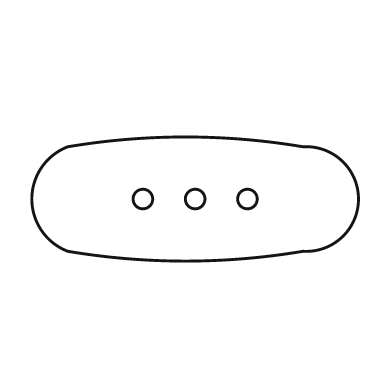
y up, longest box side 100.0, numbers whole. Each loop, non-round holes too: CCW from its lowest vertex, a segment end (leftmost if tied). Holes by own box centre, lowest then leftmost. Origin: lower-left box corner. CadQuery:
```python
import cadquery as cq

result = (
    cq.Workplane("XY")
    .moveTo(11.0, 3.0)
    .threePointArc((47.0, 0.0), (83.0, 3.0))
    .threePointArc((100.0, 19.0), (83.0, 35.0))
    .threePointArc((47.0, 38.0), (11.0, 35.0))
    .threePointArc((0.0, 19.0), (11.0, 3.0))
    .close()
    .moveTo(34.0, 19.0)
    .circle(3.0)
    .moveTo(50.0, 19.0)
    .circle(3.0)
    .moveTo(66.0, 19.0)
    .circle(3.0)
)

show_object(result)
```